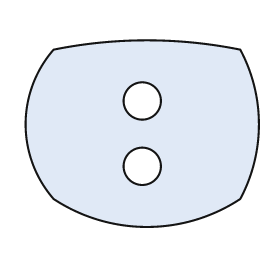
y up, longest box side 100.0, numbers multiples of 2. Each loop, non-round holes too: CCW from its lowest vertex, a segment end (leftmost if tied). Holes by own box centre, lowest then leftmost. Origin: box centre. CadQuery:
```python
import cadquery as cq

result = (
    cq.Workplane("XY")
    .moveTo(-38.0, -28.0)
    .threePointArc((2.0, -40.0), (42.0, -28.0))
    .threePointArc((50.0, 4.0), (42.0, 36.0))
    .threePointArc((2.0, 40.0), (-38.0, 36.0))
    .threePointArc((-50.0, 4.0), (-38.0, -28.0))
    .close()
    .moveTo(0.0, -14.0)
    .circle(8.0)
    .moveTo(0.0, 14.0)
    .circle(8.0)
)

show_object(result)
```